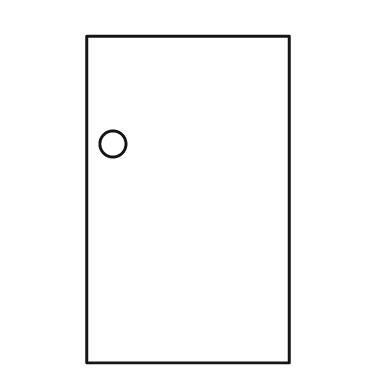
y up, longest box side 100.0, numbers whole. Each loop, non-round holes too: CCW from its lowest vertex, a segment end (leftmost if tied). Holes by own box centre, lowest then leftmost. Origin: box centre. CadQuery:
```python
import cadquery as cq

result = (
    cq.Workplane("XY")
    .moveTo(-31.0, -50.0)
    .lineTo(31.0, -50.0)
    .lineTo(31.0, 50.0)
    .lineTo(-31.0, 50.0)
    .close()
    .moveTo(-23.0, 17.0)
    .circle(4.0)
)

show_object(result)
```